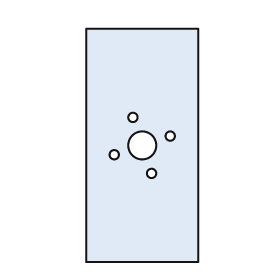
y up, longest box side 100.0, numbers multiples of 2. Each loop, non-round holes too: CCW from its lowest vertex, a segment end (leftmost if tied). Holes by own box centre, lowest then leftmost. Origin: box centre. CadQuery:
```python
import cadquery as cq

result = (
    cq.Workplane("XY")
    .moveTo(-24.0, -50.0)
    .lineTo(24.0, -50.0)
    .lineTo(24.0, 50.0)
    .lineTo(-24.0, 50.0)
    .close()
    .moveTo(4.0, -12.0)
    .circle(2.0)
    .moveTo(-12.0, -4.0)
    .circle(2.0)
    .moveTo(0.0, 0.0)
    .circle(6.0)
    .moveTo(12.0, 4.0)
    .circle(2.0)
    .moveTo(-4.0, 12.0)
    .circle(2.0)
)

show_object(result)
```